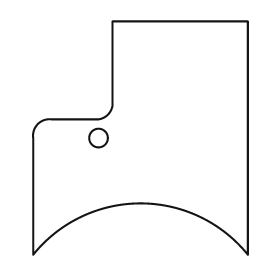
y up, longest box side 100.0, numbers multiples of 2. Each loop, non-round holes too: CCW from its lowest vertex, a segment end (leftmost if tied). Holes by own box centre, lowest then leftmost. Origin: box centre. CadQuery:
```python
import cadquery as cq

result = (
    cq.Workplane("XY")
    .moveTo(-46.0, -50.0)
    .threePointArc((0.0, -28.0), (46.0, -50.0))
    .lineTo(46.0, 50.0)
    .lineTo(-12.0, 50.0)
    .lineTo(-12.0, 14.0)
    .threePointArc((-14.0, 10.0), (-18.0, 8.0))
    .lineTo(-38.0, 8.0)
    .threePointArc((-44.0, 6.0), (-46.0, 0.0))
    .close()
    .moveTo(-18.0, 0.0)
    .circle(4.0)
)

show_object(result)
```